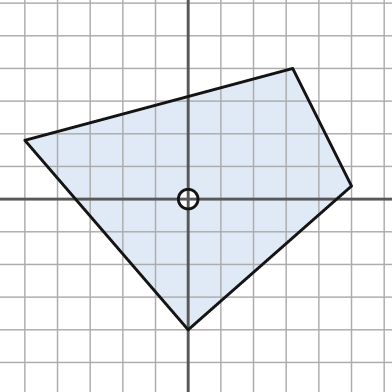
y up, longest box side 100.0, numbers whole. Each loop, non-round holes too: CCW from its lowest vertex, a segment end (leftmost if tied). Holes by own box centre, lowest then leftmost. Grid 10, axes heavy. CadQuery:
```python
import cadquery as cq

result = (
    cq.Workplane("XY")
    .moveTo(0.0, -40.0)
    .lineTo(50.0, 4.0)
    .lineTo(32.0, 40.0)
    .lineTo(-50.0, 18.0)
    .close()
    .moveTo(0.0, 0.0)
    .circle(3.0)
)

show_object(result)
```